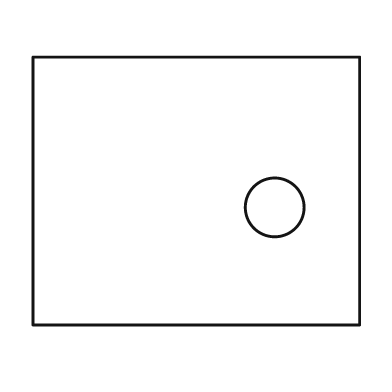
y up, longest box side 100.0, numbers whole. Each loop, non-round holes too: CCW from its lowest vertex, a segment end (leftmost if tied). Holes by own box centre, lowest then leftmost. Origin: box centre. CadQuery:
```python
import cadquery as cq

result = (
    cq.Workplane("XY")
    .moveTo(-50.0, -41.0)
    .lineTo(50.0, -41.0)
    .lineTo(50.0, 41.0)
    .lineTo(-50.0, 41.0)
    .close()
    .moveTo(24.0, -5.0)
    .circle(9.0)
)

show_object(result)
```